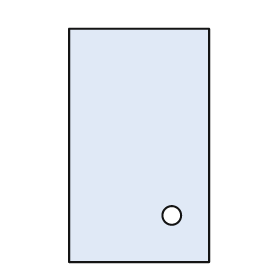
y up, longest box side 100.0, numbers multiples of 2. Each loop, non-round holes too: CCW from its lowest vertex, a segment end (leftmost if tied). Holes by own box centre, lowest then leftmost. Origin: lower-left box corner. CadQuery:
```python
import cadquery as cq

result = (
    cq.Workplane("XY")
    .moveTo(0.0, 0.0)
    .lineTo(60.0, 0.0)
    .lineTo(60.0, 100.0)
    .lineTo(0.0, 100.0)
    .close()
    .moveTo(44.0, 20.0)
    .circle(4.0)
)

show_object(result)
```